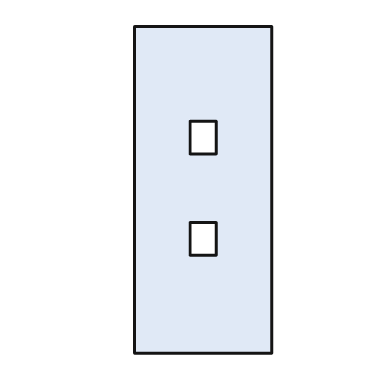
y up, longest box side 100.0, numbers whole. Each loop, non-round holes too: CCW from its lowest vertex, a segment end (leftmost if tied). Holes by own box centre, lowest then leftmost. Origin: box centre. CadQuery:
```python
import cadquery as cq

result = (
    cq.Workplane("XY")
    .moveTo(-21.0, -50.0)
    .lineTo(21.0, -50.0)
    .lineTo(21.0, 50.0)
    .lineTo(-21.0, 50.0)
    .close()
    .moveTo(-4.0, -20.0)
    .lineTo(4.0, -20.0)
    .lineTo(4.0, -10.0)
    .lineTo(-4.0, -10.0)
    .close()
    .moveTo(-4.0, 11.0)
    .lineTo(4.0, 11.0)
    .lineTo(4.0, 21.0)
    .lineTo(-4.0, 21.0)
    .close()
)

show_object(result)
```